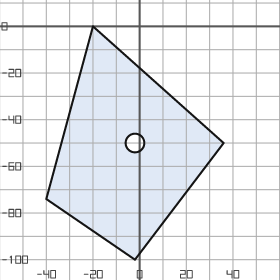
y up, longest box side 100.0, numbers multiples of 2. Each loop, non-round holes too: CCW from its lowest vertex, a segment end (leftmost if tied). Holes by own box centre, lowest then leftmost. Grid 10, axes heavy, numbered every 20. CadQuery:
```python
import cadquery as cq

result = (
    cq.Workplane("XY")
    .moveTo(-2.0, -100.0)
    .lineTo(36.0, -50.0)
    .lineTo(-20.0, 0.0)
    .lineTo(-40.0, -74.0)
    .close()
    .moveTo(-2.0, -50.0)
    .circle(4.0)
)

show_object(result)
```